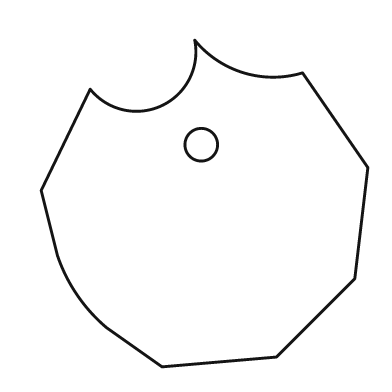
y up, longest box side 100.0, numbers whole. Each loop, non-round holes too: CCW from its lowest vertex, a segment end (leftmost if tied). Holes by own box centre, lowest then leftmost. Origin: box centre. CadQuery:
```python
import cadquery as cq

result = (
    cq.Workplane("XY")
    .moveTo(-13.0, -50.0)
    .lineTo(22.0, -47.0)
    .lineTo(46.0, -23.0)
    .lineTo(50.0, 11.0)
    .lineTo(30.0, 40.0)
    .threePointArc((12.0, 40.0), (-3.0, 50.0))
    .threePointArc((-13.0, 30.0), (-35.0, 35.0))
    .lineTo(-50.0, 4.0)
    .lineTo(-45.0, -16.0)
    .threePointArc((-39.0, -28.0), (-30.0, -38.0))
    .close()
    .moveTo(-1.0, 18.0)
    .circle(5.0)
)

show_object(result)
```